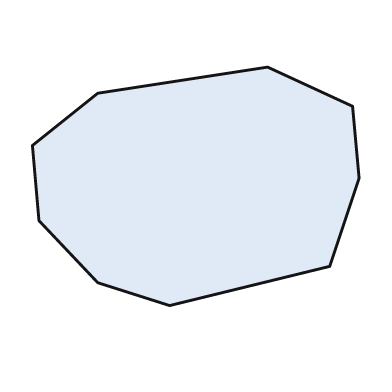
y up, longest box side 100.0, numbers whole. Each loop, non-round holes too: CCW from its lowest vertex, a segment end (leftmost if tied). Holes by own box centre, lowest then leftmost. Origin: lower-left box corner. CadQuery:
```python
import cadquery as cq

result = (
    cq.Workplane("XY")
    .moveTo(42.0, 0.0)
    .lineTo(91.0, 12.0)
    .lineTo(100.0, 39.0)
    .lineTo(98.0, 61.0)
    .lineTo(72.0, 73.0)
    .lineTo(20.0, 65.0)
    .lineTo(0.0, 49.0)
    .lineTo(2.0, 26.0)
    .lineTo(20.0, 7.0)
    .close()
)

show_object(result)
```